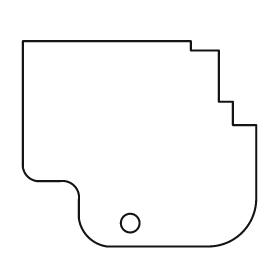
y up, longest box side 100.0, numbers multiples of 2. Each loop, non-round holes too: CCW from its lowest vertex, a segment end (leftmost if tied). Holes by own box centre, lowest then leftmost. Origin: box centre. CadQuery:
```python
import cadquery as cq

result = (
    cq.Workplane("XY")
    .moveTo(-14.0, -44.0)
    .lineTo(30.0, -44.0)
    .threePointArc((44.0, -38.0), (50.0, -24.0))
    .lineTo(50.0, 8.0)
    .lineTo(40.0, 8.0)
    .lineTo(40.0, 18.0)
    .lineTo(34.0, 18.0)
    .lineTo(34.0, 40.0)
    .lineTo(22.0, 40.0)
    .lineTo(22.0, 44.0)
    .lineTo(-50.0, 44.0)
    .lineTo(-50.0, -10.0)
    .threePointArc((-48.0, -14.0), (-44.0, -16.0))
    .lineTo(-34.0, -16.0)
    .threePointArc((-28.0, -18.0), (-26.0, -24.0))
    .lineTo(-26.0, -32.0)
    .threePointArc((-22.0, -40.0), (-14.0, -44.0))
    .close()
    .moveTo(-4.0, -34.0)
    .circle(4.0)
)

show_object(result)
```